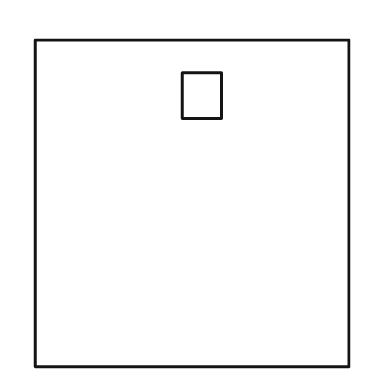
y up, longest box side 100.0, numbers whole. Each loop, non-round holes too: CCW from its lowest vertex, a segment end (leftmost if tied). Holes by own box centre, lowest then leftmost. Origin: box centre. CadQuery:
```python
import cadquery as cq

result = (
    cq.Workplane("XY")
    .moveTo(-48.0, -50.0)
    .lineTo(48.0, -50.0)
    .lineTo(48.0, 50.0)
    .lineTo(-48.0, 50.0)
    .close()
    .moveTo(-3.0, 26.0)
    .lineTo(9.0, 26.0)
    .lineTo(9.0, 40.0)
    .lineTo(-3.0, 40.0)
    .close()
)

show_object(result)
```